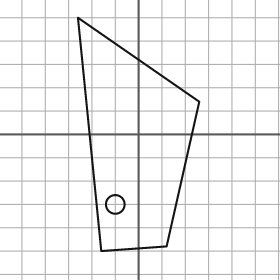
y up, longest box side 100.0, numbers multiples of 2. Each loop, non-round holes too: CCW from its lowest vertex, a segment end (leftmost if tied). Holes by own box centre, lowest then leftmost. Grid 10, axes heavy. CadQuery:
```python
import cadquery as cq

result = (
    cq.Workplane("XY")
    .moveTo(-16.0, -50.0)
    .lineTo(12.0, -48.0)
    .lineTo(26.0, 14.0)
    .lineTo(-26.0, 50.0)
    .close()
    .moveTo(-10.0, -30.0)
    .circle(4.0)
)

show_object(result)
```